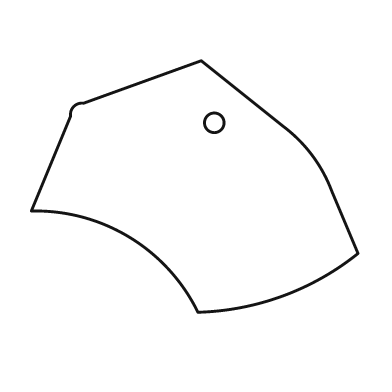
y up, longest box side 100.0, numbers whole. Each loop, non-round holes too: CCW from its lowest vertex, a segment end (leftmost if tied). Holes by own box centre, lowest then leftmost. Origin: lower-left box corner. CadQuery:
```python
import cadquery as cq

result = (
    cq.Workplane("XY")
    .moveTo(51.0, 0.0)
    .threePointArc((77.0, 5.0), (100.0, 18.0))
    .lineTo(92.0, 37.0)
    .threePointArc((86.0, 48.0), (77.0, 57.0))
    .lineTo(52.0, 77.0)
    .lineTo(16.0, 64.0)
    .threePointArc((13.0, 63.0), (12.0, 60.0))
    .lineTo(0.0, 31.0)
    .threePointArc((30.0, 23.0), (51.0, 0.0))
    .close()
    .moveTo(56.0, 58.0)
    .circle(3.0)
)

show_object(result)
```